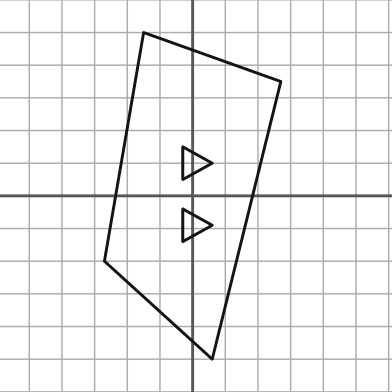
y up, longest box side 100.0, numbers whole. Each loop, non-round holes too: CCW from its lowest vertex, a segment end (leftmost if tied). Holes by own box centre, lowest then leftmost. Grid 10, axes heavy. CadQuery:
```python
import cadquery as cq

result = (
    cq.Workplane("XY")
    .moveTo(6.0, -50.0)
    .lineTo(27.0, 35.0)
    .lineTo(-15.0, 50.0)
    .lineTo(-27.0, -20.0)
    .close()
    .moveTo(-3.0, -14.0)
    .lineTo(6.0, -9.0)
    .lineTo(-3.0, -4.0)
    .close()
    .moveTo(-3.0, 5.0)
    .lineTo(6.0, 10.0)
    .lineTo(-3.0, 15.0)
    .close()
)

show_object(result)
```